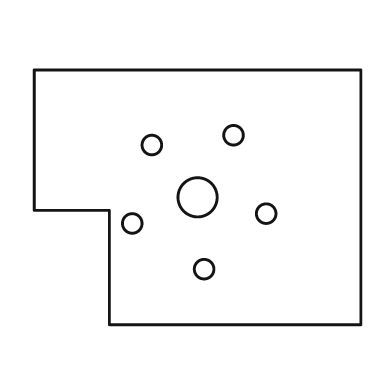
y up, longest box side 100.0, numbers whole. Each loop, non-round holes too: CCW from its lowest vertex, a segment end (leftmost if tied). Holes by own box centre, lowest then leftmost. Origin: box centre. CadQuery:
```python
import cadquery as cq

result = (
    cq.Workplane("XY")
    .moveTo(-27.0, -39.0)
    .lineTo(50.0, -39.0)
    .lineTo(50.0, 39.0)
    .lineTo(-50.0, 39.0)
    .lineTo(-50.0, -4.0)
    .lineTo(-27.0, -4.0)
    .close()
    .moveTo(2.0, -22.0)
    .circle(3.0)
    .moveTo(-20.0, -8.0)
    .circle(3.0)
    .moveTo(21.0, -5.0)
    .circle(3.0)
    .moveTo(0.0, 0.0)
    .circle(6.0)
    .moveTo(-14.0, 16.0)
    .circle(3.0)
    .moveTo(11.0, 19.0)
    .circle(3.0)
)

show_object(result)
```